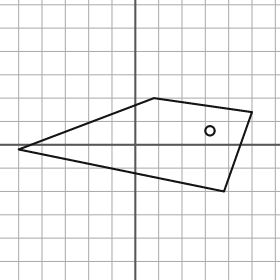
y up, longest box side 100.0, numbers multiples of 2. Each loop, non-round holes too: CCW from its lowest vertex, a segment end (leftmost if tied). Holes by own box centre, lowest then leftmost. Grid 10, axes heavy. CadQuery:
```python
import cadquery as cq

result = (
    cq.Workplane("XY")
    .moveTo(38.0, -20.0)
    .lineTo(50.0, 14.0)
    .lineTo(8.0, 20.0)
    .lineTo(-50.0, -2.0)
    .close()
    .moveTo(32.0, 6.0)
    .circle(2.0)
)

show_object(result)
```